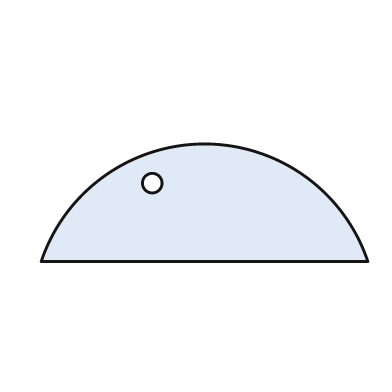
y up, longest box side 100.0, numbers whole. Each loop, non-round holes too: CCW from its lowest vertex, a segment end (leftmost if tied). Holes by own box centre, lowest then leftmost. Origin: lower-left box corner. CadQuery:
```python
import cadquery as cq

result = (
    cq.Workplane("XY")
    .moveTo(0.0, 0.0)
    .lineTo(100.0, 0.0)
    .threePointArc((50.0, 36.0), (0.0, 0.0))
    .close()
    .moveTo(34.0, 24.0)
    .circle(3.0)
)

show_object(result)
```